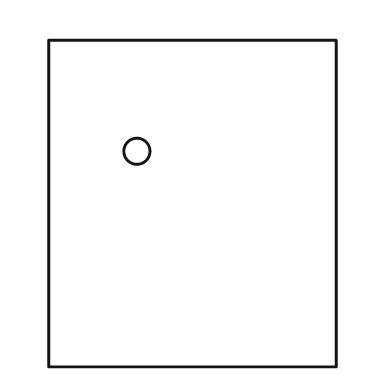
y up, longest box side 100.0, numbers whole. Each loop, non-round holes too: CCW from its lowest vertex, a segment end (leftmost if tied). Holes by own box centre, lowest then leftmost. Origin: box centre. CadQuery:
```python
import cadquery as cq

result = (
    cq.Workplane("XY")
    .moveTo(-44.0, -50.0)
    .lineTo(44.0, -50.0)
    .lineTo(44.0, 50.0)
    .lineTo(-44.0, 50.0)
    .close()
    .moveTo(-17.0, 16.0)
    .circle(4.0)
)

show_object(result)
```